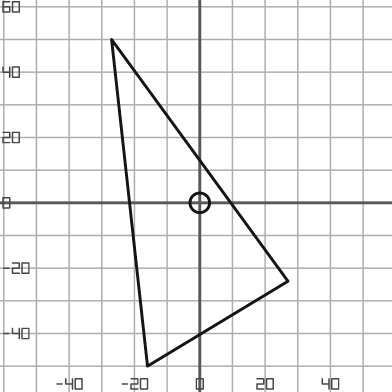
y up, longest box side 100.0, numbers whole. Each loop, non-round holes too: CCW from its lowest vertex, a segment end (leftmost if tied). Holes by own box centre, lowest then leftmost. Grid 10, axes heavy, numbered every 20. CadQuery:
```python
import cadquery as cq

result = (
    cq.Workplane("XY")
    .moveTo(-16.0, -50.0)
    .lineTo(27.0, -24.0)
    .lineTo(-27.0, 50.0)
    .close()
    .moveTo(0.0, 0.0)
    .circle(3.0)
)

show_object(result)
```